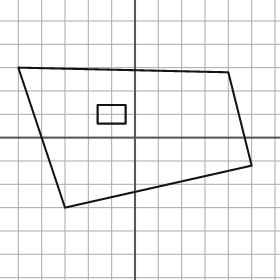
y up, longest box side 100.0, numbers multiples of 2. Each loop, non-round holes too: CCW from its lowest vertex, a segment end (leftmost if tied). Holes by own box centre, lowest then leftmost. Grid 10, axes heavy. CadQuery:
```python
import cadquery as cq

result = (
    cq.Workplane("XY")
    .moveTo(-30.0, -30.0)
    .lineTo(50.0, -12.0)
    .lineTo(40.0, 28.0)
    .lineTo(-50.0, 30.0)
    .close()
    .moveTo(-16.0, 6.0)
    .lineTo(-4.0, 6.0)
    .lineTo(-4.0, 14.0)
    .lineTo(-16.0, 14.0)
    .close()
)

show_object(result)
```